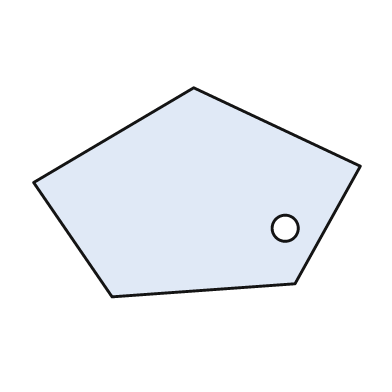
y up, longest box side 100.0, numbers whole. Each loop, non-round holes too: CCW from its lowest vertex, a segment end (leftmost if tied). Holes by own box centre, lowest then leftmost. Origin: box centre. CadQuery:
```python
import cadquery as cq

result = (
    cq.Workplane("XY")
    .moveTo(-26.0, -32.0)
    .lineTo(30.0, -28.0)
    .lineTo(50.0, 8.0)
    .lineTo(-1.0, 32.0)
    .lineTo(-50.0, 3.0)
    .close()
    .moveTo(27.0, -11.0)
    .circle(4.0)
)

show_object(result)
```